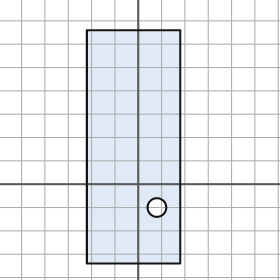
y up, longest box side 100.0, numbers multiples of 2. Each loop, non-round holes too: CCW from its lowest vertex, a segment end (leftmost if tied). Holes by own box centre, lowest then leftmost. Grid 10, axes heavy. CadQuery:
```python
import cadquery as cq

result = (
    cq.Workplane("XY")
    .moveTo(-22.0, -34.0)
    .lineTo(18.0, -34.0)
    .lineTo(18.0, 66.0)
    .lineTo(-22.0, 66.0)
    .close()
    .moveTo(8.0, -10.0)
    .circle(4.0)
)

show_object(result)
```